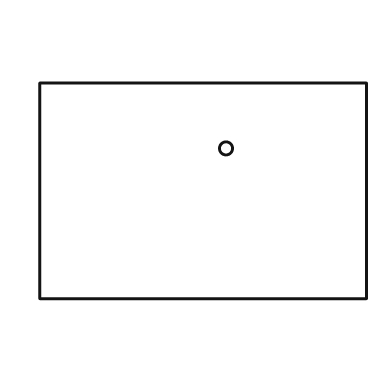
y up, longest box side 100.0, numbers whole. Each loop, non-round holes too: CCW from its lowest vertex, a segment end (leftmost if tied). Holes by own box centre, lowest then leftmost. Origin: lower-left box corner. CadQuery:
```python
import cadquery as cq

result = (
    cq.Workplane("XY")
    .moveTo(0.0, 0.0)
    .lineTo(100.0, 0.0)
    .lineTo(100.0, 66.0)
    .lineTo(0.0, 66.0)
    .close()
    .moveTo(57.0, 46.0)
    .circle(2.0)
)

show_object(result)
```